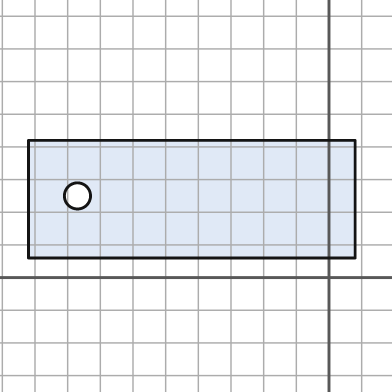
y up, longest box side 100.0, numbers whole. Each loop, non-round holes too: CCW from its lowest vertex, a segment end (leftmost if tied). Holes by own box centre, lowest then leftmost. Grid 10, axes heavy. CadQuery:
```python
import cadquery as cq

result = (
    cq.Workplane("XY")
    .moveTo(-92.0, 6.0)
    .lineTo(8.0, 6.0)
    .lineTo(8.0, 42.0)
    .lineTo(-92.0, 42.0)
    .close()
    .moveTo(-77.0, 25.0)
    .circle(4.0)
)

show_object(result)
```